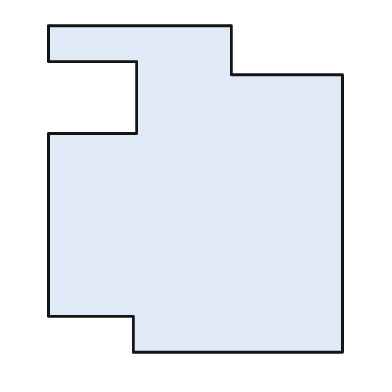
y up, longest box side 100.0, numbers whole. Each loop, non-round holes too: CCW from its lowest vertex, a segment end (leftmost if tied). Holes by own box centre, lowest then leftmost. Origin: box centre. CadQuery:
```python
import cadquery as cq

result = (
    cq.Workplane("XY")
    .moveTo(-19.0, -50.0)
    .lineTo(45.0, -50.0)
    .lineTo(45.0, 35.0)
    .lineTo(11.0, 35.0)
    .lineTo(11.0, 50.0)
    .lineTo(-45.0, 50.0)
    .lineTo(-45.0, 39.0)
    .lineTo(-18.0, 39.0)
    .lineTo(-18.0, 17.0)
    .lineTo(-45.0, 17.0)
    .lineTo(-45.0, -39.0)
    .lineTo(-19.0, -39.0)
    .close()
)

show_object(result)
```